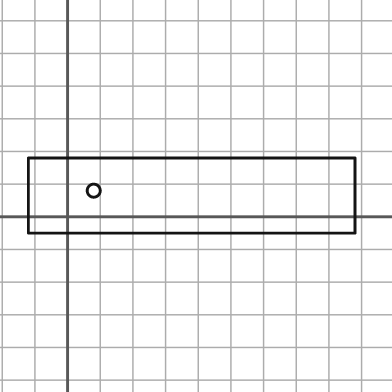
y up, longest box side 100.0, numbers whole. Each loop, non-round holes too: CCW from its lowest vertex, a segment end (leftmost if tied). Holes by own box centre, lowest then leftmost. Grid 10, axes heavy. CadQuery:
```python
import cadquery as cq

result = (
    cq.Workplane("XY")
    .moveTo(-12.0, -5.0)
    .lineTo(88.0, -5.0)
    .lineTo(88.0, 18.0)
    .lineTo(-12.0, 18.0)
    .close()
    .moveTo(8.0, 8.0)
    .circle(2.0)
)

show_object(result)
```